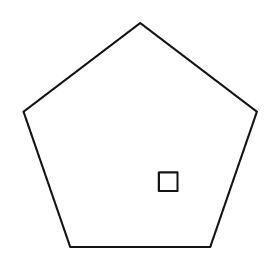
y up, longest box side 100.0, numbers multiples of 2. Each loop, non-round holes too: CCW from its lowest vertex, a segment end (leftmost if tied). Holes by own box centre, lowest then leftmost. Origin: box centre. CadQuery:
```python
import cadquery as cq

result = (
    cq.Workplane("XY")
    .moveTo(-30.0, -48.0)
    .lineTo(30.0, -48.0)
    .lineTo(50.0, 10.0)
    .lineTo(0.0, 48.0)
    .lineTo(-50.0, 10.0)
    .close()
    .moveTo(8.0, -24.0)
    .lineTo(16.0, -24.0)
    .lineTo(16.0, -16.0)
    .lineTo(8.0, -16.0)
    .close()
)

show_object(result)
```